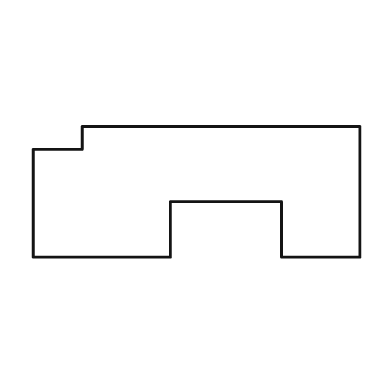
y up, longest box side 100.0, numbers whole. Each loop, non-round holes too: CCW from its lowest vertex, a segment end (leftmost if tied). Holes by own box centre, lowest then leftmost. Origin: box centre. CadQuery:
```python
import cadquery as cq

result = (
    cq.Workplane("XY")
    .moveTo(-50.0, -20.0)
    .lineTo(-8.0, -20.0)
    .lineTo(-8.0, -3.0)
    .lineTo(26.0, -3.0)
    .lineTo(26.0, -20.0)
    .lineTo(50.0, -20.0)
    .lineTo(50.0, 20.0)
    .lineTo(-35.0, 20.0)
    .lineTo(-35.0, 13.0)
    .lineTo(-50.0, 13.0)
    .close()
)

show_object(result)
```